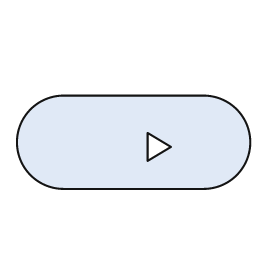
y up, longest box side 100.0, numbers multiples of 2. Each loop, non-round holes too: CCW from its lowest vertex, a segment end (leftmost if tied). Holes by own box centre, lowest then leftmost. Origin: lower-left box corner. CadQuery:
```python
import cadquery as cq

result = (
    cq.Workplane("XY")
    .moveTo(20.0, 0.0)
    .lineTo(80.0, 0.0)
    .threePointArc((100.0, 20.0), (80.0, 40.0))
    .lineTo(20.0, 40.0)
    .threePointArc((0.0, 20.0), (20.0, 0.0))
    .close()
    .moveTo(56.0, 12.0)
    .lineTo(66.0, 18.0)
    .lineTo(56.0, 24.0)
    .close()
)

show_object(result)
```